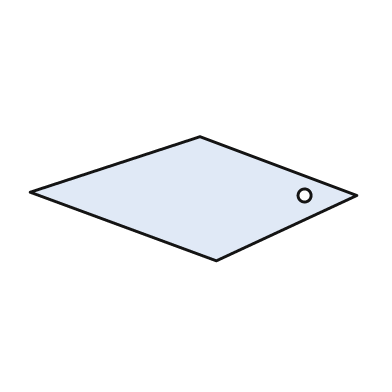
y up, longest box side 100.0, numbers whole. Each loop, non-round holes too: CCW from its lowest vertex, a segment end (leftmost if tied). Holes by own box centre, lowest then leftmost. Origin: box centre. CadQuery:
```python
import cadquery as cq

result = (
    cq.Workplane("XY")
    .moveTo(7.0, -19.0)
    .lineTo(50.0, 1.0)
    .lineTo(2.0, 19.0)
    .lineTo(-50.0, 2.0)
    .close()
    .moveTo(34.0, 1.0)
    .circle(2.0)
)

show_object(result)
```